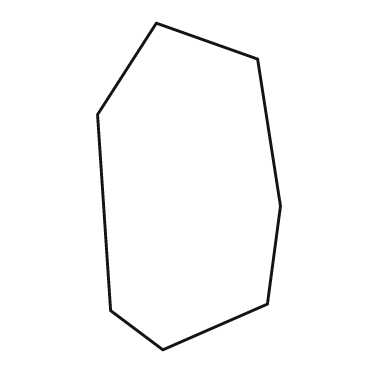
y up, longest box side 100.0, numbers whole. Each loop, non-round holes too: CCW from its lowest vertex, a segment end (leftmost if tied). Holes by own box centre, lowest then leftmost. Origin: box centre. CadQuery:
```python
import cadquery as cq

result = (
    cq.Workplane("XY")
    .moveTo(-8.0, -50.0)
    .lineTo(24.0, -36.0)
    .lineTo(28.0, -6.0)
    .lineTo(21.0, 39.0)
    .lineTo(-10.0, 50.0)
    .lineTo(-28.0, 22.0)
    .lineTo(-24.0, -38.0)
    .close()
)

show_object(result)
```